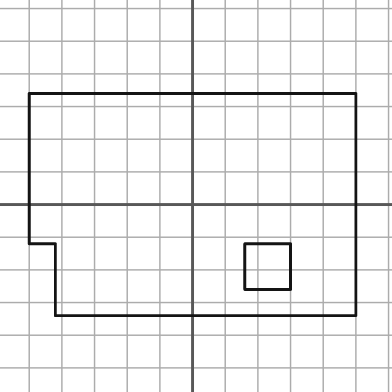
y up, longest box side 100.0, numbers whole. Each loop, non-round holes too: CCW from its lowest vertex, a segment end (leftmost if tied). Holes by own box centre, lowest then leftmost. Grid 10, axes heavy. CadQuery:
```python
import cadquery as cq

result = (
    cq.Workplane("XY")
    .moveTo(-42.0, -34.0)
    .lineTo(50.0, -34.0)
    .lineTo(50.0, 34.0)
    .lineTo(-50.0, 34.0)
    .lineTo(-50.0, -12.0)
    .lineTo(-42.0, -12.0)
    .close()
    .moveTo(16.0, -26.0)
    .lineTo(30.0, -26.0)
    .lineTo(30.0, -12.0)
    .lineTo(16.0, -12.0)
    .close()
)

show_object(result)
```